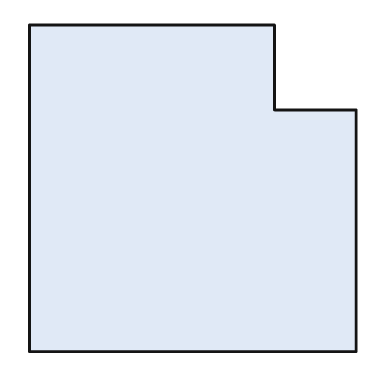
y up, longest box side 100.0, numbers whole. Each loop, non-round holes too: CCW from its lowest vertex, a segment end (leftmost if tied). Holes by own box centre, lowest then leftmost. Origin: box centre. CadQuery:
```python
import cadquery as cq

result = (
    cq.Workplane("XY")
    .moveTo(-50.0, -50.0)
    .lineTo(50.0, -50.0)
    .lineTo(50.0, 24.0)
    .lineTo(25.0, 24.0)
    .lineTo(25.0, 50.0)
    .lineTo(-50.0, 50.0)
    .close()
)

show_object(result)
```